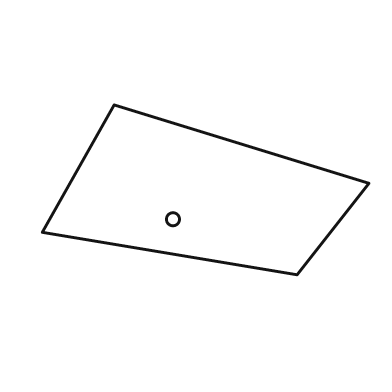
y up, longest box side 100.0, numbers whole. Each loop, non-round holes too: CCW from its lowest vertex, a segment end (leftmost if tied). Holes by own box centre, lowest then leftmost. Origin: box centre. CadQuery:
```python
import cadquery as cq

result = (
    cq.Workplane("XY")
    .moveTo(28.0, -26.0)
    .lineTo(50.0, 2.0)
    .lineTo(-28.0, 26.0)
    .lineTo(-50.0, -13.0)
    .close()
    .moveTo(-10.0, -9.0)
    .circle(2.0)
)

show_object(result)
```